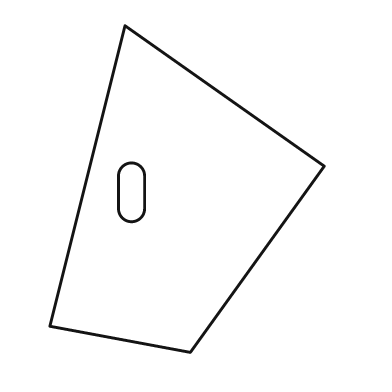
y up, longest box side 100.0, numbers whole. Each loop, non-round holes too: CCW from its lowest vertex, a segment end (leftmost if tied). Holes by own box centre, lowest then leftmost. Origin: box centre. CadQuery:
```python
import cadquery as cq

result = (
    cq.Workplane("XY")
    .moveTo(1.0, -50.0)
    .lineTo(42.0, 7.0)
    .lineTo(-19.0, 50.0)
    .lineTo(-42.0, -42.0)
    .close()
    .moveTo(-21.0, -6.0)
    .threePointArc((-17.0, -10.0), (-13.0, -6.0))
    .lineTo(-13.0, 4.0)
    .threePointArc((-17.0, 8.0), (-21.0, 4.0))
    .close()
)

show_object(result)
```